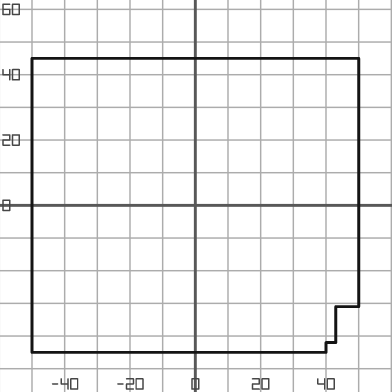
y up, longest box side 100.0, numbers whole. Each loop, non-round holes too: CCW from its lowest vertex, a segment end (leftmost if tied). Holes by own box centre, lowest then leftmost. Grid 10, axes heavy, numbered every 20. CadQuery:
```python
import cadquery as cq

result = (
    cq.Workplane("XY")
    .moveTo(-50.0, -45.0)
    .lineTo(40.0, -45.0)
    .lineTo(40.0, -42.0)
    .lineTo(43.0, -42.0)
    .lineTo(43.0, -31.0)
    .lineTo(50.0, -31.0)
    .lineTo(50.0, 45.0)
    .lineTo(-50.0, 45.0)
    .close()
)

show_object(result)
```